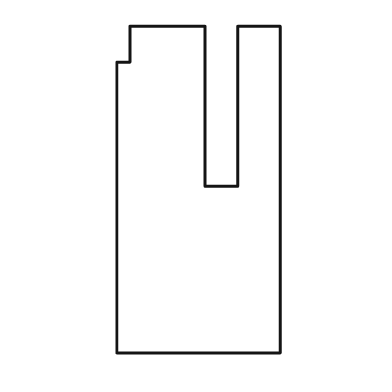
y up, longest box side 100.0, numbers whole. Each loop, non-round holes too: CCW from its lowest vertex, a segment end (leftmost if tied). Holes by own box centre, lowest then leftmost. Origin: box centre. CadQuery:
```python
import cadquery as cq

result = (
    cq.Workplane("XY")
    .moveTo(-25.0, -50.0)
    .lineTo(25.0, -50.0)
    .lineTo(25.0, 50.0)
    .lineTo(12.0, 50.0)
    .lineTo(12.0, 1.0)
    .lineTo(2.0, 1.0)
    .lineTo(2.0, 50.0)
    .lineTo(-21.0, 50.0)
    .lineTo(-21.0, 39.0)
    .lineTo(-25.0, 39.0)
    .close()
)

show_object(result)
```